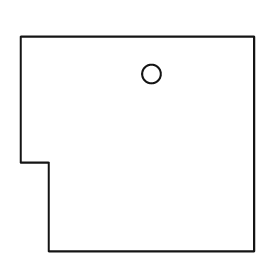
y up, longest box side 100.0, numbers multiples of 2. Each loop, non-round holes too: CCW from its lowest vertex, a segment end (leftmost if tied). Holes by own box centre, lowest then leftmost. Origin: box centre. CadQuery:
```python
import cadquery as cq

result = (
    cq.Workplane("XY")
    .moveTo(-38.0, -46.0)
    .lineTo(50.0, -46.0)
    .lineTo(50.0, 46.0)
    .lineTo(-50.0, 46.0)
    .lineTo(-50.0, -8.0)
    .lineTo(-38.0, -8.0)
    .close()
    .moveTo(6.0, 30.0)
    .circle(4.0)
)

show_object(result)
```